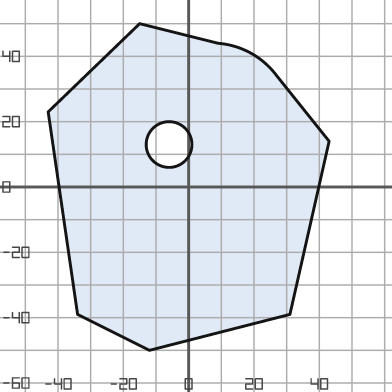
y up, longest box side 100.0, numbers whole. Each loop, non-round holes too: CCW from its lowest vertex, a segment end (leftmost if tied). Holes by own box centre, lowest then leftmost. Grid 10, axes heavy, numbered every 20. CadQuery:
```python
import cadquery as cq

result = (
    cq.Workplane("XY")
    .moveTo(-12.0, -50.0)
    .lineTo(31.0, -39.0)
    .lineTo(43.0, 14.0)
    .lineTo(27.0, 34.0)
    .threePointArc((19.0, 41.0), (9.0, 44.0))
    .lineTo(-15.0, 50.0)
    .lineTo(-43.0, 23.0)
    .lineTo(-34.0, -39.0)
    .close()
    .moveTo(-6.0, 13.0)
    .circle(7.0)
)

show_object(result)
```